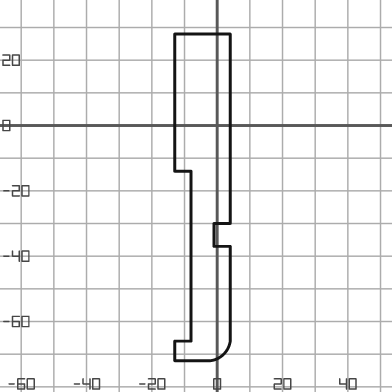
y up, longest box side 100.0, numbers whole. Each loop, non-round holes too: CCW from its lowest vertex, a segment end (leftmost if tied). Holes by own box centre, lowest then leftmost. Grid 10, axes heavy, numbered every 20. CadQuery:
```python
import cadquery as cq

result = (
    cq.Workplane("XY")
    .moveTo(-13.0, -72.0)
    .lineTo(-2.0, -72.0)
    .threePointArc((2.0, -70.0), (4.0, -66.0))
    .lineTo(4.0, -37.0)
    .lineTo(-1.0, -37.0)
    .lineTo(-1.0, -30.0)
    .lineTo(4.0, -30.0)
    .lineTo(4.0, 28.0)
    .lineTo(-13.0, 28.0)
    .lineTo(-13.0, -14.0)
    .lineTo(-8.0, -14.0)
    .lineTo(-8.0, -66.0)
    .lineTo(-13.0, -66.0)
    .close()
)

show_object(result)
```